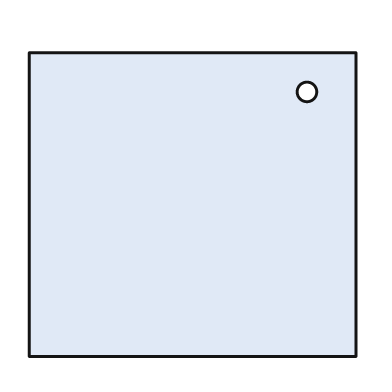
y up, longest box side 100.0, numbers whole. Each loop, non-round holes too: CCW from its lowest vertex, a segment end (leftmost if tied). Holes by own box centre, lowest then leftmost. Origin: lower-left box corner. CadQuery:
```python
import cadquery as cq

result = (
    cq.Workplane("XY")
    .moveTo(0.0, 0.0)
    .lineTo(100.0, 0.0)
    .lineTo(100.0, 93.0)
    .lineTo(0.0, 93.0)
    .close()
    .moveTo(85.0, 81.0)
    .circle(3.0)
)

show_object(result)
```